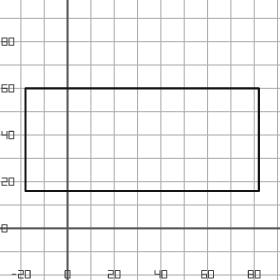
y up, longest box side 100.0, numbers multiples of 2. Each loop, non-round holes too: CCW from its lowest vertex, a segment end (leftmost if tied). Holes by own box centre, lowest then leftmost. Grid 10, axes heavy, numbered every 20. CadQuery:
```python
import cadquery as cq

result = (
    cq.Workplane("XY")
    .moveTo(-18.0, 16.0)
    .lineTo(82.0, 16.0)
    .lineTo(82.0, 60.0)
    .lineTo(-18.0, 60.0)
    .close()
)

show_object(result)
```